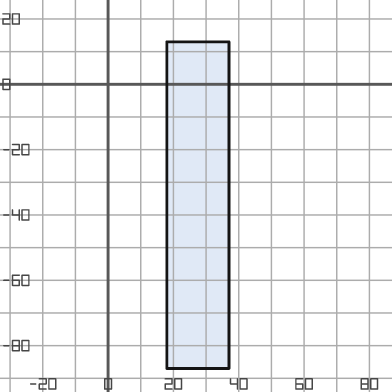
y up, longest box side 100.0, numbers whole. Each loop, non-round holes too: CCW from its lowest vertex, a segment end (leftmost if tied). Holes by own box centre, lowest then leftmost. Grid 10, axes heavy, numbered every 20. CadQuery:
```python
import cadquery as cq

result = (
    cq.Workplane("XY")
    .moveTo(18.0, -87.0)
    .lineTo(37.0, -87.0)
    .lineTo(37.0, 13.0)
    .lineTo(18.0, 13.0)
    .close()
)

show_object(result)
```